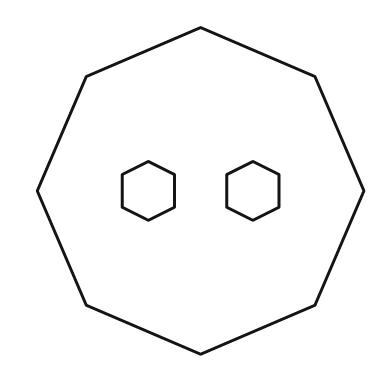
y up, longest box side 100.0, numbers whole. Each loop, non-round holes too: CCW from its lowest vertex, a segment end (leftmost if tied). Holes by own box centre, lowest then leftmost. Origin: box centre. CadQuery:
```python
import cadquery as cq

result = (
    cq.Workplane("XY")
    .moveTo(0.0, -50.0)
    .lineTo(35.0, -35.0)
    .lineTo(50.0, 0.0)
    .lineTo(35.0, 35.0)
    .lineTo(0.0, 50.0)
    .lineTo(-35.0, 35.0)
    .lineTo(-50.0, 0.0)
    .lineTo(-35.0, -35.0)
    .close()
    .moveTo(-16.0, -9.0)
    .lineTo(-8.0, -5.0)
    .lineTo(-8.0, 5.0)
    .lineTo(-16.0, 9.0)
    .lineTo(-24.0, 5.0)
    .lineTo(-24.0, -5.0)
    .close()
    .moveTo(16.0, -9.0)
    .lineTo(24.0, -5.0)
    .lineTo(24.0, 5.0)
    .lineTo(16.0, 9.0)
    .lineTo(8.0, 5.0)
    .lineTo(8.0, -5.0)
    .close()
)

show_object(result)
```